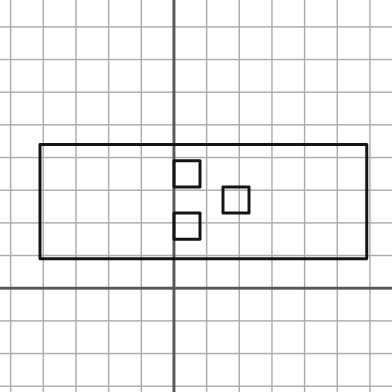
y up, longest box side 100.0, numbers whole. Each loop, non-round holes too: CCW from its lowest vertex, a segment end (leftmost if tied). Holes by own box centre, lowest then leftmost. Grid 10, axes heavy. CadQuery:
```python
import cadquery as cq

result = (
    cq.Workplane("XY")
    .moveTo(-41.0, 9.0)
    .lineTo(59.0, 9.0)
    .lineTo(59.0, 44.0)
    .lineTo(-41.0, 44.0)
    .close()
    .moveTo(0.0, 15.0)
    .lineTo(8.0, 15.0)
    .lineTo(8.0, 23.0)
    .lineTo(0.0, 23.0)
    .close()
    .moveTo(15.0, 23.0)
    .lineTo(23.0, 23.0)
    .lineTo(23.0, 31.0)
    .lineTo(15.0, 31.0)
    .close()
    .moveTo(0.0, 31.0)
    .lineTo(8.0, 31.0)
    .lineTo(8.0, 39.0)
    .lineTo(0.0, 39.0)
    .close()
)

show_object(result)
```